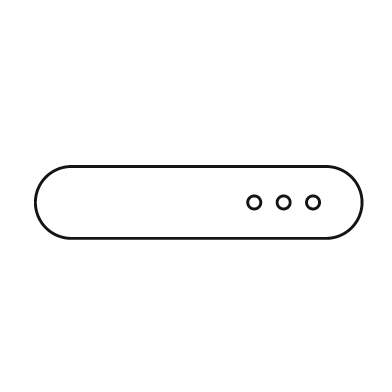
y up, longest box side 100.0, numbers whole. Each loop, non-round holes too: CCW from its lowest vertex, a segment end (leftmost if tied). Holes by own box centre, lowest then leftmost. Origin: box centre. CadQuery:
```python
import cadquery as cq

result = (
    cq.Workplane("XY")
    .moveTo(-39.0, -11.0)
    .lineTo(39.0, -11.0)
    .threePointArc((50.0, 0.0), (39.0, 11.0))
    .lineTo(-39.0, 11.0)
    .threePointArc((-50.0, 0.0), (-39.0, -11.0))
    .close()
    .moveTo(17.0, 0.0)
    .circle(2.0)
    .moveTo(26.0, 0.0)
    .circle(2.0)
    .moveTo(35.0, 0.0)
    .circle(2.0)
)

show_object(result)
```